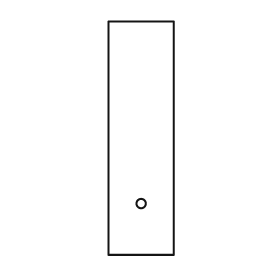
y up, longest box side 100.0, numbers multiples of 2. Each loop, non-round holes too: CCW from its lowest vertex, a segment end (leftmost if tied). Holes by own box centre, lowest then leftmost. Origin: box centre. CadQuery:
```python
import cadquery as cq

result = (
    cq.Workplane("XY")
    .moveTo(-14.0, -50.0)
    .lineTo(14.0, -50.0)
    .lineTo(14.0, 50.0)
    .lineTo(-14.0, 50.0)
    .close()
    .moveTo(0.0, -28.0)
    .circle(2.0)
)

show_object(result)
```